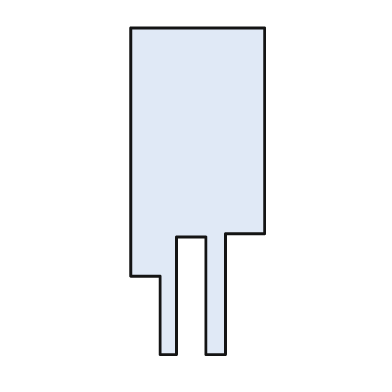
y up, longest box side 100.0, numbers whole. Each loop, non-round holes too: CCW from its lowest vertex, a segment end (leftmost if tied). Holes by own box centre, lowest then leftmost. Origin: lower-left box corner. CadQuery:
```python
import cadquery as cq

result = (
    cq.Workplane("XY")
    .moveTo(9.0, 0.0)
    .lineTo(14.0, 0.0)
    .lineTo(14.0, 36.0)
    .lineTo(23.0, 36.0)
    .lineTo(23.0, 0.0)
    .lineTo(29.0, 0.0)
    .lineTo(29.0, 37.0)
    .lineTo(41.0, 37.0)
    .lineTo(41.0, 100.0)
    .lineTo(0.0, 100.0)
    .lineTo(0.0, 24.0)
    .lineTo(9.0, 24.0)
    .close()
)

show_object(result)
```